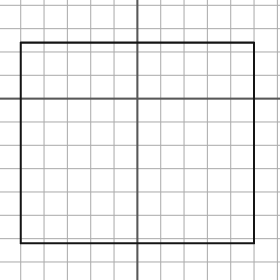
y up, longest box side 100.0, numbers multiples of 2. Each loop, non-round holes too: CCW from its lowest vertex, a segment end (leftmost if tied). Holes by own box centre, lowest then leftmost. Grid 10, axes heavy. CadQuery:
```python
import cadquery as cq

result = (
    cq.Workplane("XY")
    .moveTo(-50.0, -62.0)
    .lineTo(50.0, -62.0)
    .lineTo(50.0, 24.0)
    .lineTo(-50.0, 24.0)
    .close()
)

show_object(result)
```